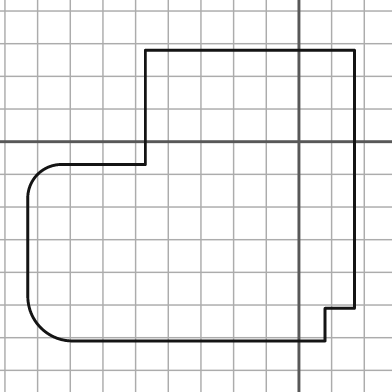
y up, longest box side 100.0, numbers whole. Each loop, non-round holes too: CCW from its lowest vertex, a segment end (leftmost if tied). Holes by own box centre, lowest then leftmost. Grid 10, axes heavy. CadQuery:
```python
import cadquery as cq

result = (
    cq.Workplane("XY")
    .moveTo(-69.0, -61.0)
    .lineTo(8.0, -61.0)
    .lineTo(8.0, -51.0)
    .lineTo(17.0, -51.0)
    .lineTo(17.0, 28.0)
    .lineTo(-47.0, 28.0)
    .lineTo(-47.0, -7.0)
    .lineTo(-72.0, -7.0)
    .threePointArc((-80.0, -10.0), (-83.0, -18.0))
    .lineTo(-83.0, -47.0)
    .threePointArc((-79.0, -57.0), (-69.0, -61.0))
    .close()
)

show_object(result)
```